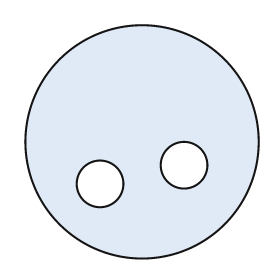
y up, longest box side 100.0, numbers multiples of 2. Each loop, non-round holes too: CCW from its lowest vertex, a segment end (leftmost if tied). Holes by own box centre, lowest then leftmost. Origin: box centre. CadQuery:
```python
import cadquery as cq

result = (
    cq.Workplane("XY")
    .moveTo(0.0, 0.0)
    .circle(50.0)
    .moveTo(-18.0, -18.0)
    .circle(10.0)
    .moveTo(18.0, -10.0)
    .circle(10.0)
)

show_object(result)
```